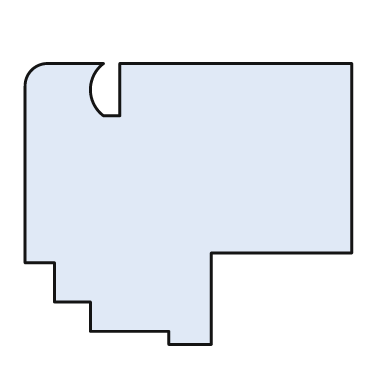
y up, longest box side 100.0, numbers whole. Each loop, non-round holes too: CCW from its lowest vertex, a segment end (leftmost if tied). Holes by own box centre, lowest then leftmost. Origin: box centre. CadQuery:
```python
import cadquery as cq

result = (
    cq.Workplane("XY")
    .moveTo(-6.0, -43.0)
    .lineTo(7.0, -43.0)
    .lineTo(7.0, -15.0)
    .lineTo(50.0, -15.0)
    .lineTo(50.0, 43.0)
    .lineTo(-21.0, 43.0)
    .lineTo(-21.0, 27.0)
    .lineTo(-26.0, 27.0)
    .threePointArc((-30.0, 35.0), (-26.0, 43.0))
    .lineTo(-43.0, 43.0)
    .threePointArc((-48.0, 41.0), (-50.0, 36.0))
    .lineTo(-50.0, -18.0)
    .lineTo(-41.0, -18.0)
    .lineTo(-41.0, -30.0)
    .lineTo(-30.0, -30.0)
    .lineTo(-30.0, -39.0)
    .lineTo(-6.0, -39.0)
    .close()
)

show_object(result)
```